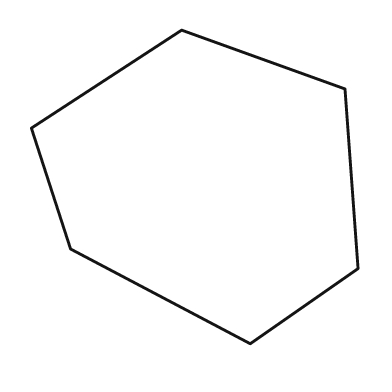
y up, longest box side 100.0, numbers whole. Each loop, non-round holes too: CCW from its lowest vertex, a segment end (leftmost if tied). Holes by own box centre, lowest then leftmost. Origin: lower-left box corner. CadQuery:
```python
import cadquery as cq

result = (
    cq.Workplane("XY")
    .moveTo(67.0, 0.0)
    .lineTo(100.0, 23.0)
    .lineTo(96.0, 78.0)
    .lineTo(46.0, 96.0)
    .lineTo(0.0, 66.0)
    .lineTo(12.0, 29.0)
    .close()
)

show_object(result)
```